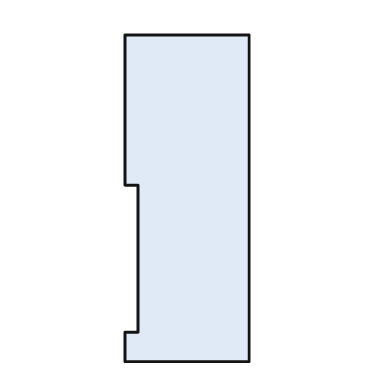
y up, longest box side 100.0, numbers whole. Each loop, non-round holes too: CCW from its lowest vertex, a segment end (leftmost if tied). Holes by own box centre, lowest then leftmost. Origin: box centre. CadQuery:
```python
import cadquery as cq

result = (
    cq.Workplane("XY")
    .moveTo(-19.0, -50.0)
    .lineTo(19.0, -50.0)
    .lineTo(19.0, 50.0)
    .lineTo(-19.0, 50.0)
    .lineTo(-19.0, 4.0)
    .lineTo(-15.0, 4.0)
    .lineTo(-15.0, -41.0)
    .lineTo(-19.0, -41.0)
    .close()
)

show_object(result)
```